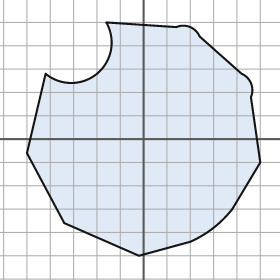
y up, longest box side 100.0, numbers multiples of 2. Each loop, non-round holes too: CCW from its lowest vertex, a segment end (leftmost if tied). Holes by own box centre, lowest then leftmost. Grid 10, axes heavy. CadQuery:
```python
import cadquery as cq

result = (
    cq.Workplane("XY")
    .moveTo(-2.0, -50.0)
    .lineTo(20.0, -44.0)
    .threePointArc((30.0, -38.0), (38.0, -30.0))
    .lineTo(50.0, -10.0)
    .lineTo(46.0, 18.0)
    .threePointArc((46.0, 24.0), (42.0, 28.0))
    .lineTo(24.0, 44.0)
    .threePointArc((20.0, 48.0), (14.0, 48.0))
    .lineTo(-16.0, 50.0)
    .threePointArc((-20.0, 28.0), (-42.0, 28.0))
    .lineTo(-50.0, -6.0)
    .lineTo(-34.0, -36.0)
    .close()
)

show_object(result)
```